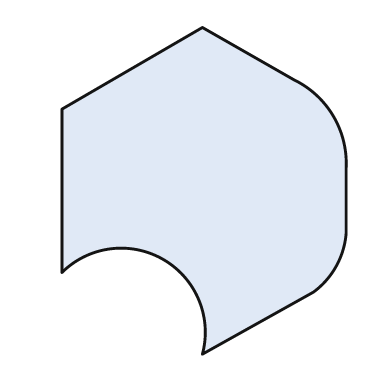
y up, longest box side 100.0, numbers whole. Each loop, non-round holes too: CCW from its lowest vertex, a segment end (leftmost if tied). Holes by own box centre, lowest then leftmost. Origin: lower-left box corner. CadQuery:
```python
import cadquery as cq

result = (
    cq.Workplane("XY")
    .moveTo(43.0, 0.0)
    .lineTo(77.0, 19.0)
    .threePointArc((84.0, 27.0), (87.0, 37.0))
    .lineTo(87.0, 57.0)
    .threePointArc((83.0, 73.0), (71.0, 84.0))
    .lineTo(43.0, 100.0)
    .lineTo(0.0, 75.0)
    .lineTo(0.0, 25.0)
    .threePointArc((31.0, 29.0), (43.0, 0.0))
    .close()
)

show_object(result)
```